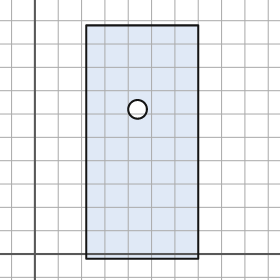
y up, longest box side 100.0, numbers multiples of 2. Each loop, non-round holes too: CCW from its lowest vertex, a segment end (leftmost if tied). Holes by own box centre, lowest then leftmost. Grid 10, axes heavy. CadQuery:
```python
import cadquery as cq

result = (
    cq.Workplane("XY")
    .moveTo(22.0, -2.0)
    .lineTo(70.0, -2.0)
    .lineTo(70.0, 98.0)
    .lineTo(22.0, 98.0)
    .close()
    .moveTo(44.0, 62.0)
    .circle(4.0)
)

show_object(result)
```